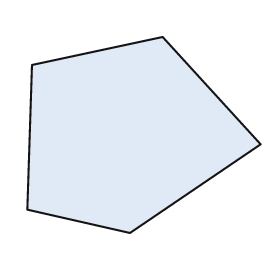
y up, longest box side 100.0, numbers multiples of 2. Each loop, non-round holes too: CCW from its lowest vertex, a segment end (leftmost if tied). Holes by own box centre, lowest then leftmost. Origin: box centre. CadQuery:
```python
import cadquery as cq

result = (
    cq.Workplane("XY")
    .moveTo(-6.0, -42.0)
    .lineTo(50.0, -4.0)
    .lineTo(8.0, 42.0)
    .lineTo(-48.0, 30.0)
    .lineTo(-50.0, -32.0)
    .close()
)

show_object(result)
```